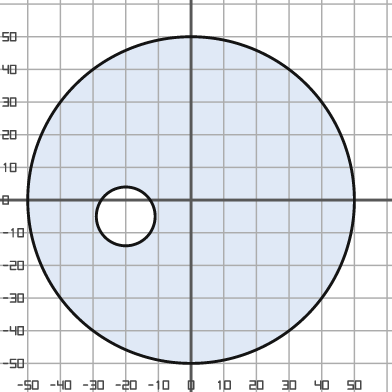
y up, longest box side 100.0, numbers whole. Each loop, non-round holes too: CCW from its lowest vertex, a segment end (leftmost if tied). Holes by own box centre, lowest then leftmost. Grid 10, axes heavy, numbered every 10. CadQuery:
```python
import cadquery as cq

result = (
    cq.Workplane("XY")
    .moveTo(0.0, 0.0)
    .circle(50.0)
    .moveTo(-20.0, -5.0)
    .circle(9.0)
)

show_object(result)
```